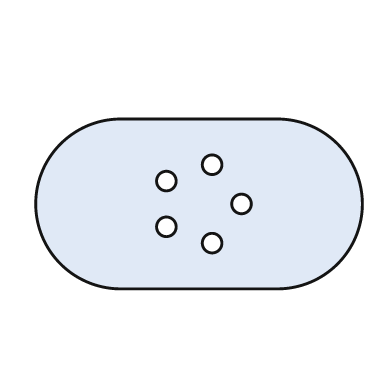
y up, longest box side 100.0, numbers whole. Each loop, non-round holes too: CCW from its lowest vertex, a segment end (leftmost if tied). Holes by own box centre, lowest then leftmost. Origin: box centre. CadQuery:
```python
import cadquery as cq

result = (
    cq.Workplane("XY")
    .moveTo(-24.0, -26.0)
    .lineTo(24.0, -26.0)
    .threePointArc((50.0, 0.0), (24.0, 26.0))
    .lineTo(-24.0, 26.0)
    .threePointArc((-50.0, 0.0), (-24.0, -26.0))
    .close()
    .moveTo(4.0, -12.0)
    .circle(3.0)
    .moveTo(-10.0, -7.0)
    .circle(3.0)
    .moveTo(13.0, 0.0)
    .circle(3.0)
    .moveTo(-10.0, 7.0)
    .circle(3.0)
    .moveTo(4.0, 12.0)
    .circle(3.0)
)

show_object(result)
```